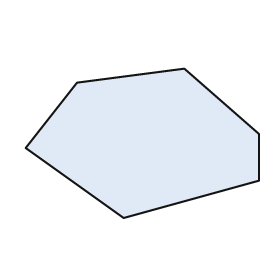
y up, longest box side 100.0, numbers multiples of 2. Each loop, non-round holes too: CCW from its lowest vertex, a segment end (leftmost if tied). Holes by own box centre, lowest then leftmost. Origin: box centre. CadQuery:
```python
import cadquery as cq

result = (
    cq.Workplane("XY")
    .moveTo(-8.0, -32.0)
    .lineTo(50.0, -16.0)
    .lineTo(50.0, 4.0)
    .lineTo(18.0, 32.0)
    .lineTo(-28.0, 26.0)
    .lineTo(-50.0, -2.0)
    .close()
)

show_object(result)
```